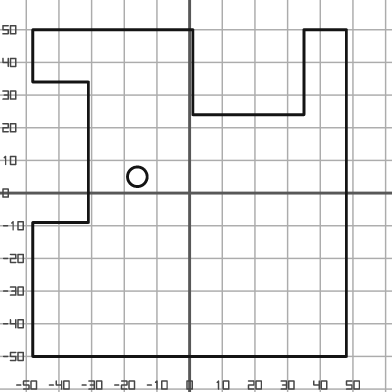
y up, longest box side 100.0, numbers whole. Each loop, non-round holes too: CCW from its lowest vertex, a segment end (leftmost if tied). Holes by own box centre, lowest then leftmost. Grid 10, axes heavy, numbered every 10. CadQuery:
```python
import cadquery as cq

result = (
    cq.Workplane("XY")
    .moveTo(-48.0, -50.0)
    .lineTo(48.0, -50.0)
    .lineTo(48.0, 50.0)
    .lineTo(35.0, 50.0)
    .lineTo(35.0, 24.0)
    .lineTo(1.0, 24.0)
    .lineTo(1.0, 50.0)
    .lineTo(-48.0, 50.0)
    .lineTo(-48.0, 34.0)
    .lineTo(-31.0, 34.0)
    .lineTo(-31.0, -9.0)
    .lineTo(-48.0, -9.0)
    .close()
    .moveTo(-16.0, 5.0)
    .circle(3.0)
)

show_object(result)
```